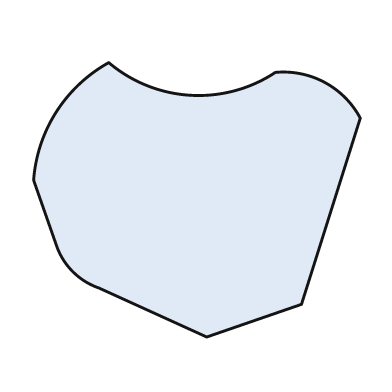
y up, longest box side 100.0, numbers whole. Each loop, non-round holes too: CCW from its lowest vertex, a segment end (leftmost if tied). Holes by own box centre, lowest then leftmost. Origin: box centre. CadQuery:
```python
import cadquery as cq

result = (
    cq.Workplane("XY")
    .moveTo(3.0, -42.0)
    .lineTo(32.0, -32.0)
    .lineTo(50.0, 25.0)
    .threePointArc((39.0, 36.0), (24.0, 39.0))
    .threePointArc((-2.0, 32.0), (-27.0, 42.0))
    .threePointArc((-43.0, 27.0), (-50.0, 6.0))
    .lineTo(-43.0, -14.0)
    .threePointArc((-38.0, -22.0), (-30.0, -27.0))
    .close()
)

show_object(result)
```